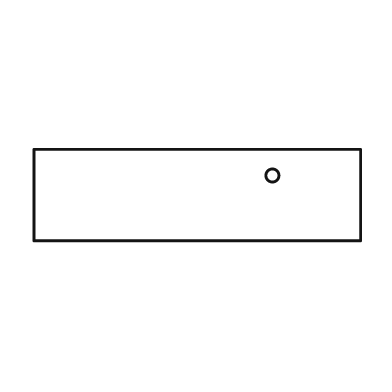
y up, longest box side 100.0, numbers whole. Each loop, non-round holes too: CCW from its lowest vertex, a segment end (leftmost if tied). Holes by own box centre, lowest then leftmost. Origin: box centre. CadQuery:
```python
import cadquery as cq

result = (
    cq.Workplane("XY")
    .moveTo(-50.0, -14.0)
    .lineTo(50.0, -14.0)
    .lineTo(50.0, 14.0)
    .lineTo(-50.0, 14.0)
    .close()
    .moveTo(23.0, 6.0)
    .circle(2.0)
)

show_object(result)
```